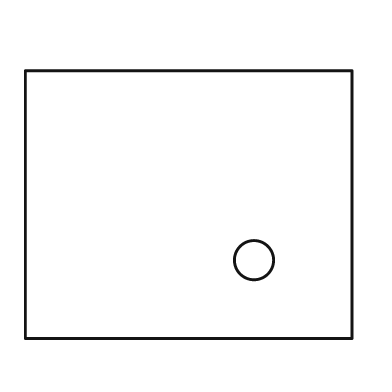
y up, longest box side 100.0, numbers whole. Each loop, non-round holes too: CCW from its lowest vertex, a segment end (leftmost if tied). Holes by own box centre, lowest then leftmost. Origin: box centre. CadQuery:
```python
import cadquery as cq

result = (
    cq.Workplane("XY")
    .moveTo(-50.0, -41.0)
    .lineTo(50.0, -41.0)
    .lineTo(50.0, 41.0)
    .lineTo(-50.0, 41.0)
    .close()
    .moveTo(20.0, -17.0)
    .circle(6.0)
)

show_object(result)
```